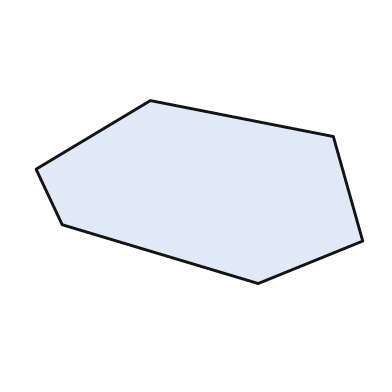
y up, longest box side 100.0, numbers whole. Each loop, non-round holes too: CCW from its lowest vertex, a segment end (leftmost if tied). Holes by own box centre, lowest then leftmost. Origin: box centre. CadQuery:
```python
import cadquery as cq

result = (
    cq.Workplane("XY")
    .moveTo(18.0, -28.0)
    .lineTo(50.0, -15.0)
    .lineTo(41.0, 17.0)
    .lineTo(-15.0, 28.0)
    .lineTo(-50.0, 7.0)
    .lineTo(-42.0, -10.0)
    .close()
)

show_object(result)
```